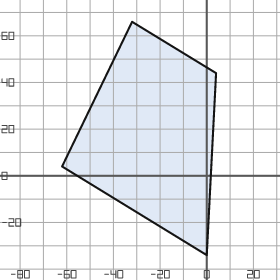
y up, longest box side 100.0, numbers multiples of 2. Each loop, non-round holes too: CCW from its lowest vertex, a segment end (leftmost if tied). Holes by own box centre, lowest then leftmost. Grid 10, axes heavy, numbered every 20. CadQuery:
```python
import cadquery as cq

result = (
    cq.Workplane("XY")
    .moveTo(0.0, -34.0)
    .lineTo(4.0, 44.0)
    .lineTo(-32.0, 66.0)
    .lineTo(-62.0, 4.0)
    .close()
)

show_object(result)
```